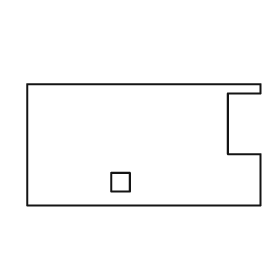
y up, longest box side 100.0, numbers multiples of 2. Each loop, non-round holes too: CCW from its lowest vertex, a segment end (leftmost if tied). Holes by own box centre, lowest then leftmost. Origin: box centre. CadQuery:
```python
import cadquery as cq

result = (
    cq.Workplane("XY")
    .moveTo(-50.0, -26.0)
    .lineTo(50.0, -26.0)
    .lineTo(50.0, -4.0)
    .lineTo(36.0, -4.0)
    .lineTo(36.0, 22.0)
    .lineTo(50.0, 22.0)
    .lineTo(50.0, 26.0)
    .lineTo(-50.0, 26.0)
    .close()
    .moveTo(-14.0, -20.0)
    .lineTo(-6.0, -20.0)
    .lineTo(-6.0, -12.0)
    .lineTo(-14.0, -12.0)
    .close()
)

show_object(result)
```